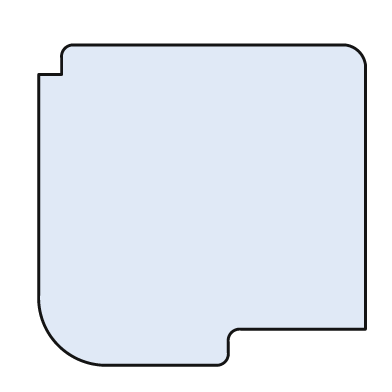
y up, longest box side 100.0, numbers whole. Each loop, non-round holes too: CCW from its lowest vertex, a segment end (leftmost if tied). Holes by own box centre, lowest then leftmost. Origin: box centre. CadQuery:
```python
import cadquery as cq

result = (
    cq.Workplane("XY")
    .moveTo(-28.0, -49.0)
    .lineTo(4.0, -49.0)
    .threePointArc((7.0, -48.0), (8.0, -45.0))
    .lineTo(8.0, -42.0)
    .threePointArc((9.0, -39.0), (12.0, -38.0))
    .lineTo(50.0, -38.0)
    .lineTo(50.0, 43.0)
    .threePointArc((48.0, 47.0), (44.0, 49.0))
    .lineTo(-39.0, 49.0)
    .threePointArc((-42.0, 48.0), (-43.0, 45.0))
    .lineTo(-43.0, 40.0)
    .lineTo(-50.0, 40.0)
    .lineTo(-50.0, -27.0)
    .threePointArc((-44.0, -43.0), (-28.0, -49.0))
    .close()
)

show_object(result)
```